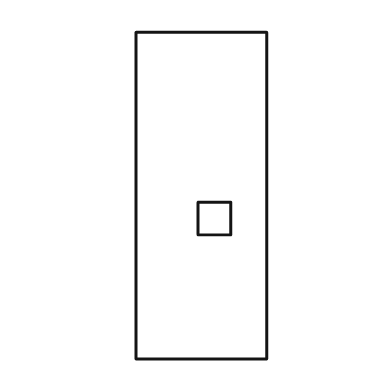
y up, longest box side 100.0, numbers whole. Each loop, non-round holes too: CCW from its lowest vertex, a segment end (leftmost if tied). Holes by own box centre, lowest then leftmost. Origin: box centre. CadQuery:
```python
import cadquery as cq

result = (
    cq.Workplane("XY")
    .moveTo(-20.0, -50.0)
    .lineTo(20.0, -50.0)
    .lineTo(20.0, 50.0)
    .lineTo(-20.0, 50.0)
    .close()
    .moveTo(-1.0, -12.0)
    .lineTo(9.0, -12.0)
    .lineTo(9.0, -2.0)
    .lineTo(-1.0, -2.0)
    .close()
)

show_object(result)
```